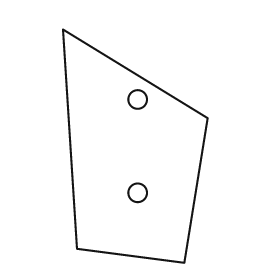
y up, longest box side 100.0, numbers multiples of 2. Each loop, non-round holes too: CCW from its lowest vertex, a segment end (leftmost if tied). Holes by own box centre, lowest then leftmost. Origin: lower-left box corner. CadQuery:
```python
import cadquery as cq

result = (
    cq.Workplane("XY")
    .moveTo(52.0, 0.0)
    .lineTo(62.0, 62.0)
    .lineTo(0.0, 100.0)
    .lineTo(6.0, 6.0)
    .close()
    .moveTo(32.0, 30.0)
    .circle(4.0)
    .moveTo(32.0, 70.0)
    .circle(4.0)
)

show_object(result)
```